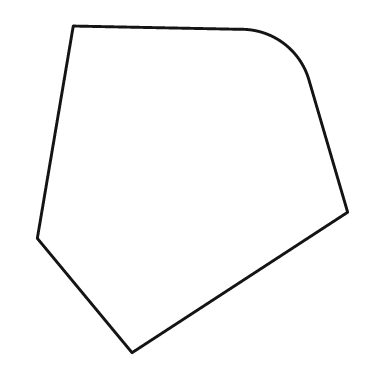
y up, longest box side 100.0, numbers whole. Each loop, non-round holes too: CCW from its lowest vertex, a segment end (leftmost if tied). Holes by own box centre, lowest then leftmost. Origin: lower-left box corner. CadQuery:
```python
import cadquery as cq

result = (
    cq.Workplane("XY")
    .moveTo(29.0, 0.0)
    .lineTo(95.0, 43.0)
    .lineTo(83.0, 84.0)
    .threePointArc((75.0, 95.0), (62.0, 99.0))
    .lineTo(11.0, 100.0)
    .lineTo(0.0, 35.0)
    .close()
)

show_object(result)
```